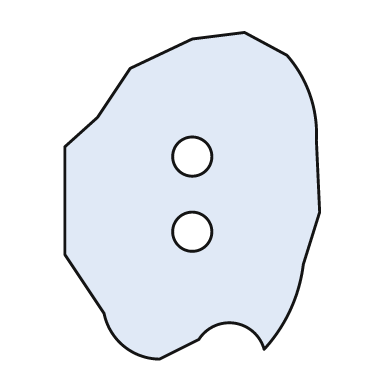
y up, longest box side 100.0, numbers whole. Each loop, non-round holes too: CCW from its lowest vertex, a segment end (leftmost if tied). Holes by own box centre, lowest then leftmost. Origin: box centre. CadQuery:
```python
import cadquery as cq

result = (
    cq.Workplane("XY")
    .moveTo(-10.0, -50.0)
    .lineTo(2.0, -44.0)
    .threePointArc((13.0, -39.0), (22.0, -47.0))
    .threePointArc((30.0, -35.0), (34.0, -21.0))
    .lineTo(39.0, -5.0)
    .lineTo(38.0, 17.0)
    .threePointArc((36.0, 31.0), (29.0, 43.0))
    .lineTo(16.0, 50.0)
    .lineTo(0.0, 48.0)
    .lineTo(-19.0, 39.0)
    .lineTo(-29.0, 24.0)
    .lineTo(-39.0, 15.0)
    .lineTo(-39.0, -18.0)
    .lineTo(-27.0, -36.0)
    .threePointArc((-21.0, -46.0), (-10.0, -50.0))
    .close()
    .moveTo(0.0, -11.0)
    .circle(6.0)
    .moveTo(0.0, 12.0)
    .circle(6.0)
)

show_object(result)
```